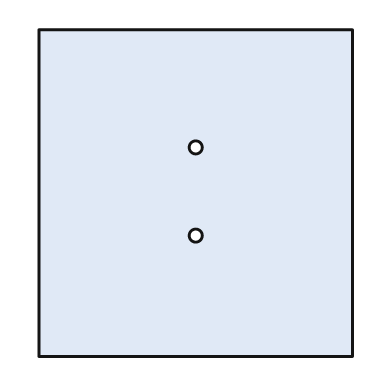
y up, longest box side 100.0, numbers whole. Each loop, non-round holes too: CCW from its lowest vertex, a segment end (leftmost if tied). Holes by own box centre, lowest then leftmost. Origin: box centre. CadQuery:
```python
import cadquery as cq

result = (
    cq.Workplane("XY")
    .moveTo(-48.0, -50.0)
    .lineTo(48.0, -50.0)
    .lineTo(48.0, 50.0)
    .lineTo(-48.0, 50.0)
    .close()
    .moveTo(0.0, -13.0)
    .circle(2.0)
    .moveTo(0.0, 14.0)
    .circle(2.0)
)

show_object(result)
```